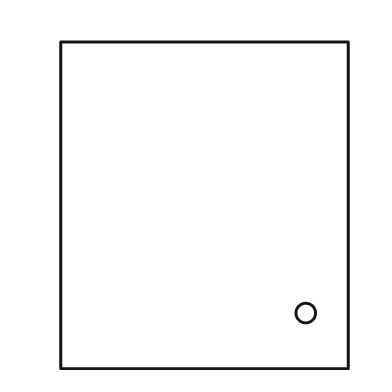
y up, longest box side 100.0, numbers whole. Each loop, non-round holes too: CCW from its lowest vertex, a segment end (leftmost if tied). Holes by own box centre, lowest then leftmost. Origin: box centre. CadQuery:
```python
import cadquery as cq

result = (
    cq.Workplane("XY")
    .moveTo(-44.0, -50.0)
    .lineTo(44.0, -50.0)
    .lineTo(44.0, 50.0)
    .lineTo(-44.0, 50.0)
    .close()
    .moveTo(31.0, -33.0)
    .circle(3.0)
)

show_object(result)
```